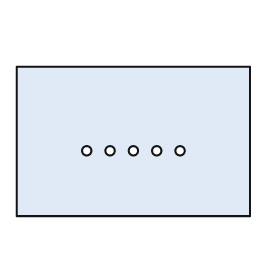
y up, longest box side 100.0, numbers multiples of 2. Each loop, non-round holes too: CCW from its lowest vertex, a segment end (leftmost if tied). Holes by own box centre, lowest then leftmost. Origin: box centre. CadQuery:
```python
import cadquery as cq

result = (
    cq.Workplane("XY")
    .moveTo(-50.0, -32.0)
    .lineTo(50.0, -32.0)
    .lineTo(50.0, 32.0)
    .lineTo(-50.0, 32.0)
    .close()
    .moveTo(-20.0, -4.0)
    .circle(2.0)
    .moveTo(-10.0, -4.0)
    .circle(2.0)
    .moveTo(0.0, -4.0)
    .circle(2.0)
    .moveTo(10.0, -4.0)
    .circle(2.0)
    .moveTo(20.0, -4.0)
    .circle(2.0)
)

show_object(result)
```